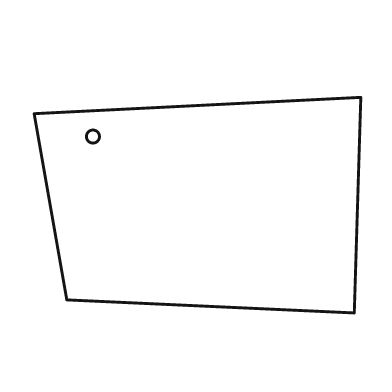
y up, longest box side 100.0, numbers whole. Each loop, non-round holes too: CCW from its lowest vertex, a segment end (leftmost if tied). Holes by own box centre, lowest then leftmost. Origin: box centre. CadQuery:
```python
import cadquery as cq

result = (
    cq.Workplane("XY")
    .moveTo(48.0, -33.0)
    .lineTo(50.0, 33.0)
    .lineTo(-50.0, 28.0)
    .lineTo(-40.0, -29.0)
    .close()
    .moveTo(-32.0, 21.0)
    .circle(2.0)
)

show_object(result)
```